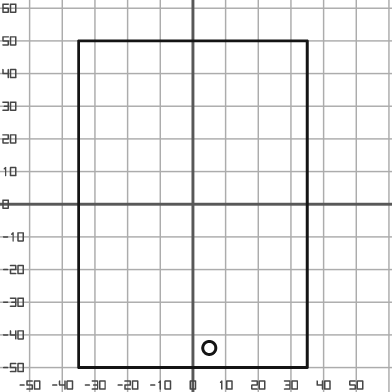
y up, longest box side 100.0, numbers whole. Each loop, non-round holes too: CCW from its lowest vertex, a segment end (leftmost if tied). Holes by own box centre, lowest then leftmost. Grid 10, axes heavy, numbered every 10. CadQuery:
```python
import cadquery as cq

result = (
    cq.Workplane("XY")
    .moveTo(-35.0, -50.0)
    .lineTo(35.0, -50.0)
    .lineTo(35.0, 50.0)
    .lineTo(-35.0, 50.0)
    .close()
    .moveTo(5.0, -44.0)
    .circle(2.0)
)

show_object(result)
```